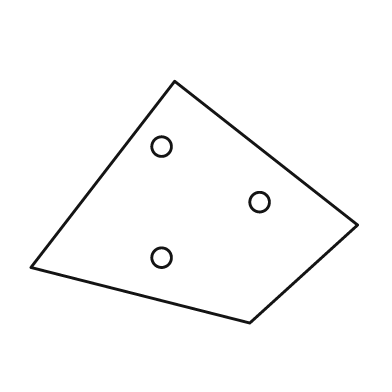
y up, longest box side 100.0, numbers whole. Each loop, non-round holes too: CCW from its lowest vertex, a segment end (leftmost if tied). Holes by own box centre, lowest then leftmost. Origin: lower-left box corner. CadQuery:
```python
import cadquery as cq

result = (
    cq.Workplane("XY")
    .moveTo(67.0, 0.0)
    .lineTo(100.0, 30.0)
    .lineTo(44.0, 74.0)
    .lineTo(0.0, 17.0)
    .close()
    .moveTo(40.0, 20.0)
    .circle(3.0)
    .moveTo(70.0, 37.0)
    .circle(3.0)
    .moveTo(40.0, 54.0)
    .circle(3.0)
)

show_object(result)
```